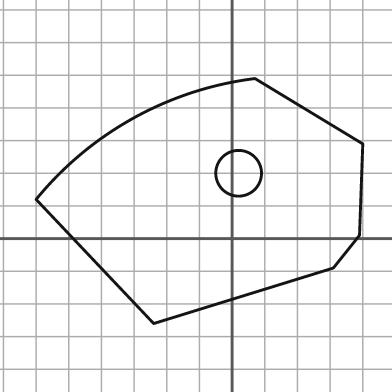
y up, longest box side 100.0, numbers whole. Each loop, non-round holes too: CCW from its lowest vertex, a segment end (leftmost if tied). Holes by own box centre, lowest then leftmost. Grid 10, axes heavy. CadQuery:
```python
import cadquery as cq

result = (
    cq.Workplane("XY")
    .moveTo(-24.0, -26.0)
    .lineTo(31.0, -9.0)
    .lineTo(39.0, 1.0)
    .lineTo(40.0, 29.0)
    .lineTo(7.0, 49.0)
    .threePointArc((-30.0, 37.0), (-60.0, 12.0))
    .close()
    .moveTo(2.0, 20.0)
    .circle(7.0)
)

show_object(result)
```